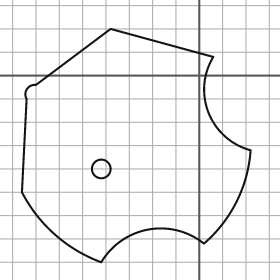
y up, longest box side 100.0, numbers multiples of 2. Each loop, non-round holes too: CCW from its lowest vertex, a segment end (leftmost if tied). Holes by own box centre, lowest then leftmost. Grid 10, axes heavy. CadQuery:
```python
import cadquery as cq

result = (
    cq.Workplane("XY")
    .moveTo(-42.0, -80.0)
    .threePointArc((-22.0, -66.0), (2.0, -72.0))
    .threePointArc((16.0, -54.0), (22.0, -32.0))
    .threePointArc((4.0, -16.0), (6.0, 8.0))
    .lineTo(-38.0, 20.0)
    .lineTo(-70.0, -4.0)
    .threePointArc((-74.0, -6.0), (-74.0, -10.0))
    .lineTo(-76.0, -50.0)
    .threePointArc((-62.0, -68.0), (-42.0, -80.0))
    .close()
    .moveTo(-42.0, -40.0)
    .circle(4.0)
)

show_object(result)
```